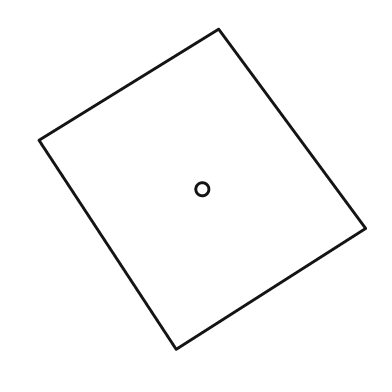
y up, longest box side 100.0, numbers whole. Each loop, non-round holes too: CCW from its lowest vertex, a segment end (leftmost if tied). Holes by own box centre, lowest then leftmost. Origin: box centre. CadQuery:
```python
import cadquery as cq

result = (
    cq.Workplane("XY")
    .moveTo(-8.0, -49.0)
    .lineTo(50.0, -12.0)
    .lineTo(5.0, 49.0)
    .lineTo(-50.0, 15.0)
    .close()
    .moveTo(0.0, 0.0)
    .circle(2.0)
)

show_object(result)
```